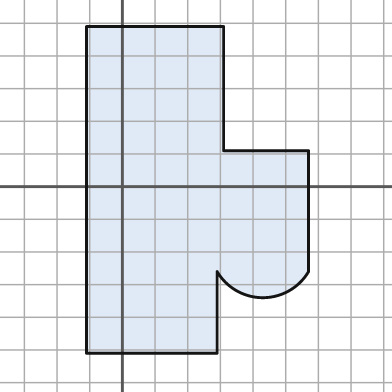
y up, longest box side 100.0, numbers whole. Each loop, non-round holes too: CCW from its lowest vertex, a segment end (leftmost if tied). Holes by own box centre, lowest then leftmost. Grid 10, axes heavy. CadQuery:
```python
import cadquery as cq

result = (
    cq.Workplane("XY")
    .moveTo(-11.0, -51.0)
    .lineTo(29.0, -51.0)
    .lineTo(29.0, -26.0)
    .threePointArc((43.0, -34.0), (57.0, -26.0))
    .lineTo(57.0, 11.0)
    .lineTo(31.0, 11.0)
    .lineTo(31.0, 49.0)
    .lineTo(-11.0, 49.0)
    .close()
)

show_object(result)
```